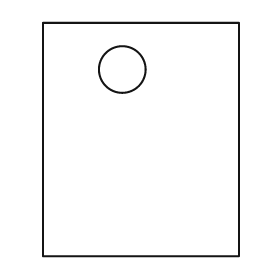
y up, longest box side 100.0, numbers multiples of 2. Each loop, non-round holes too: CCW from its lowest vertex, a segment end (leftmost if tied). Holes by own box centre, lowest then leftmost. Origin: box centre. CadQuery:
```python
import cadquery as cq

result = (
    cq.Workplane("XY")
    .moveTo(-42.0, -50.0)
    .lineTo(42.0, -50.0)
    .lineTo(42.0, 50.0)
    .lineTo(-42.0, 50.0)
    .close()
    .moveTo(-8.0, 30.0)
    .circle(10.0)
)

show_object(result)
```